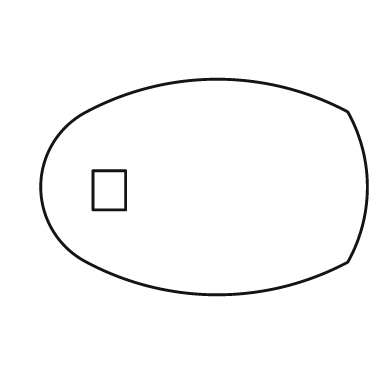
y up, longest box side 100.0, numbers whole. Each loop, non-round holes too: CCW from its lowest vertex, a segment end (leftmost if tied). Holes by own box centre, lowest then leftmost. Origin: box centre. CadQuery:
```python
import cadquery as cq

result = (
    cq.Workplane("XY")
    .moveTo(-36.0, -23.0)
    .threePointArc((4.0, -33.0), (44.0, -23.0))
    .threePointArc((50.0, 0.0), (44.0, 23.0))
    .threePointArc((4.0, 33.0), (-36.0, 23.0))
    .threePointArc((-50.0, 0.0), (-36.0, -23.0))
    .close()
    .moveTo(-34.0, -7.0)
    .lineTo(-24.0, -7.0)
    .lineTo(-24.0, 5.0)
    .lineTo(-34.0, 5.0)
    .close()
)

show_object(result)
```